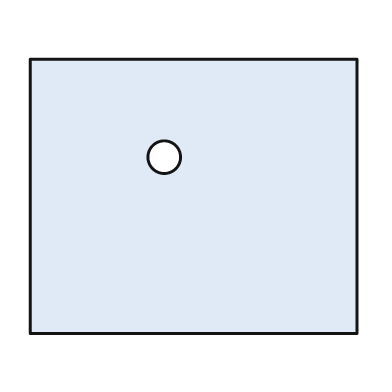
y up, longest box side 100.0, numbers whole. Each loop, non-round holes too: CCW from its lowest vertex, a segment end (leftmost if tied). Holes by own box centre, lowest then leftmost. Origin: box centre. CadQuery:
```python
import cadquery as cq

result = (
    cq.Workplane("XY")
    .moveTo(-50.0, -42.0)
    .lineTo(50.0, -42.0)
    .lineTo(50.0, 42.0)
    .lineTo(-50.0, 42.0)
    .close()
    .moveTo(-9.0, 12.0)
    .circle(5.0)
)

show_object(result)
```